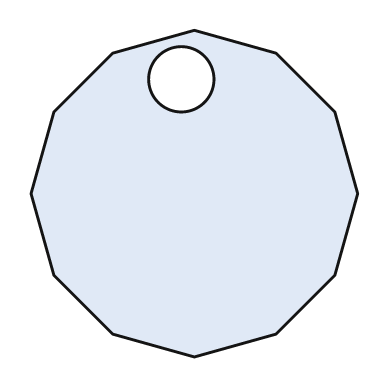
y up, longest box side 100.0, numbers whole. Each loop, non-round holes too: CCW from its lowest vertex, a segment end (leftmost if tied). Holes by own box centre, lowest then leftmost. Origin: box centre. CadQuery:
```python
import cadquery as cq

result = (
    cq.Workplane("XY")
    .moveTo(0.0, -50.0)
    .lineTo(25.0, -43.0)
    .lineTo(43.0, -25.0)
    .lineTo(50.0, 0.0)
    .lineTo(43.0, 25.0)
    .lineTo(25.0, 43.0)
    .lineTo(0.0, 50.0)
    .lineTo(-25.0, 43.0)
    .lineTo(-43.0, 25.0)
    .lineTo(-50.0, 0.0)
    .lineTo(-43.0, -25.0)
    .lineTo(-25.0, -43.0)
    .close()
    .moveTo(-4.0, 35.0)
    .circle(10.0)
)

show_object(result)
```